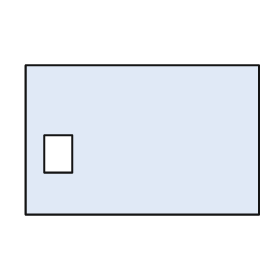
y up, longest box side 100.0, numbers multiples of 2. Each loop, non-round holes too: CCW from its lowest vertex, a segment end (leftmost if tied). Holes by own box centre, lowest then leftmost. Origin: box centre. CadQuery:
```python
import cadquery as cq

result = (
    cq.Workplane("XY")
    .moveTo(-50.0, -32.0)
    .lineTo(50.0, -32.0)
    .lineTo(50.0, 32.0)
    .lineTo(-50.0, 32.0)
    .close()
    .moveTo(-42.0, -14.0)
    .lineTo(-30.0, -14.0)
    .lineTo(-30.0, 2.0)
    .lineTo(-42.0, 2.0)
    .close()
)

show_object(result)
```